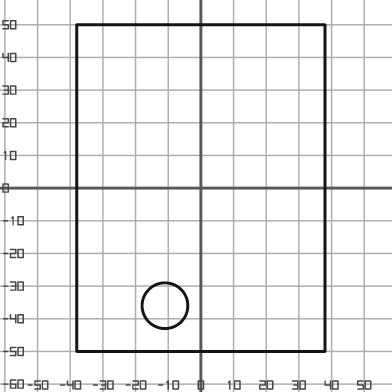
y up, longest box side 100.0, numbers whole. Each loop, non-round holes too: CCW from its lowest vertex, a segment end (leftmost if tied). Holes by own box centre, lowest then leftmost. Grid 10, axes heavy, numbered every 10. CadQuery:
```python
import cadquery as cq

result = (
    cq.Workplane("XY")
    .moveTo(-38.0, -50.0)
    .lineTo(38.0, -50.0)
    .lineTo(38.0, 50.0)
    .lineTo(-38.0, 50.0)
    .close()
    .moveTo(-11.0, -36.0)
    .circle(7.0)
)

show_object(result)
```